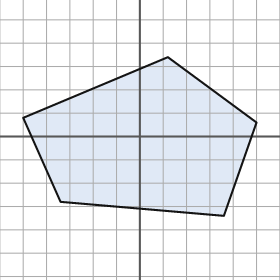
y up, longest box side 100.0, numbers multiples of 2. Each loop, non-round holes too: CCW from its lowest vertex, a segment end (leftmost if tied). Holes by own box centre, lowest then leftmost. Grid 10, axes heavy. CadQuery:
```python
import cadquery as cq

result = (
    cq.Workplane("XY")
    .moveTo(36.0, -34.0)
    .lineTo(50.0, 6.0)
    .lineTo(12.0, 34.0)
    .lineTo(-50.0, 8.0)
    .lineTo(-34.0, -28.0)
    .close()
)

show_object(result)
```